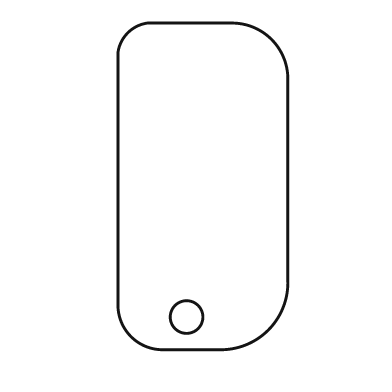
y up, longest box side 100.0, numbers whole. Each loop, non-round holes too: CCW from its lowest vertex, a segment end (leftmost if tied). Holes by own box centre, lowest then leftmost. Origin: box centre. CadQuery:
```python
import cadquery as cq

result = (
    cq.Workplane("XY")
    .moveTo(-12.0, -50.0)
    .lineTo(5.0, -50.0)
    .threePointArc((20.0, -44.0), (26.0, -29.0))
    .lineTo(26.0, 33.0)
    .threePointArc((21.0, 45.0), (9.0, 50.0))
    .lineTo(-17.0, 50.0)
    .threePointArc((-23.0, 47.0), (-26.0, 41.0))
    .lineTo(-26.0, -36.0)
    .threePointArc((-22.0, -46.0), (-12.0, -50.0))
    .close()
    .moveTo(-5.0, -40.0)
    .circle(5.0)
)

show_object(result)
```